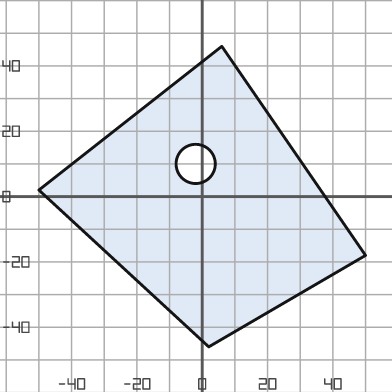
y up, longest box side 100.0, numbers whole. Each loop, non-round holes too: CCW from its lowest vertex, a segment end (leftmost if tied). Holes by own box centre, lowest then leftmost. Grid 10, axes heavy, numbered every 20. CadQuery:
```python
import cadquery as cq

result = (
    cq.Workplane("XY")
    .moveTo(2.0, -46.0)
    .lineTo(50.0, -18.0)
    .lineTo(6.0, 46.0)
    .lineTo(-50.0, 2.0)
    .close()
    .moveTo(-2.0, 10.0)
    .circle(6.0)
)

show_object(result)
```